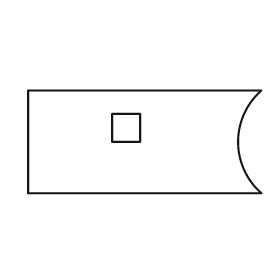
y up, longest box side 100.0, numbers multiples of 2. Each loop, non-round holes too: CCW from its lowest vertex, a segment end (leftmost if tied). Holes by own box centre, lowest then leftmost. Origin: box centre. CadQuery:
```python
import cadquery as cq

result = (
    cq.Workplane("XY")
    .moveTo(-50.0, -22.0)
    .lineTo(50.0, -22.0)
    .threePointArc((40.0, 0.0), (50.0, 22.0))
    .lineTo(-50.0, 22.0)
    .close()
    .moveTo(-14.0, 0.0)
    .lineTo(-2.0, 0.0)
    .lineTo(-2.0, 12.0)
    .lineTo(-14.0, 12.0)
    .close()
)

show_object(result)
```